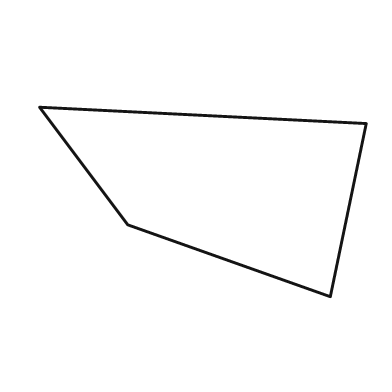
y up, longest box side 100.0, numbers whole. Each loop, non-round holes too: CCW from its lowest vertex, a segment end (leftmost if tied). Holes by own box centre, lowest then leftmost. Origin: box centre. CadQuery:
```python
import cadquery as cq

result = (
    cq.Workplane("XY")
    .moveTo(39.0, -29.0)
    .lineTo(50.0, 24.0)
    .lineTo(-50.0, 29.0)
    .lineTo(-23.0, -7.0)
    .close()
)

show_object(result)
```